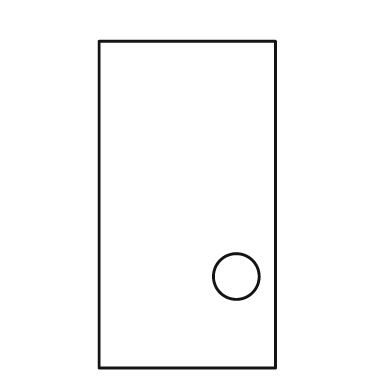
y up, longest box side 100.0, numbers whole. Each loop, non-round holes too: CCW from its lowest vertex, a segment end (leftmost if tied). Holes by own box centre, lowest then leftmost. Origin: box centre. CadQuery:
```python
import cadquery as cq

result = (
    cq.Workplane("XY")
    .moveTo(-27.0, -50.0)
    .lineTo(27.0, -50.0)
    .lineTo(27.0, 50.0)
    .lineTo(-27.0, 50.0)
    .close()
    .moveTo(15.0, -22.0)
    .circle(7.0)
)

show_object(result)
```